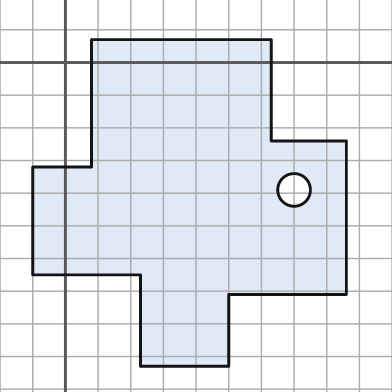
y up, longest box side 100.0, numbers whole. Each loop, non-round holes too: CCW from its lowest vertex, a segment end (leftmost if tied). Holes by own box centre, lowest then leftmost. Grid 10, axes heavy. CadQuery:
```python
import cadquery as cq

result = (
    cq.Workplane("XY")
    .moveTo(23.0, -93.0)
    .lineTo(50.0, -93.0)
    .lineTo(50.0, -71.0)
    .lineTo(86.0, -71.0)
    .lineTo(86.0, -24.0)
    .lineTo(63.0, -24.0)
    .lineTo(63.0, 7.0)
    .lineTo(8.0, 7.0)
    .lineTo(8.0, -32.0)
    .lineTo(-10.0, -32.0)
    .lineTo(-10.0, -65.0)
    .lineTo(23.0, -65.0)
    .close()
    .moveTo(70.0, -39.0)
    .circle(5.0)
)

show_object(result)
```